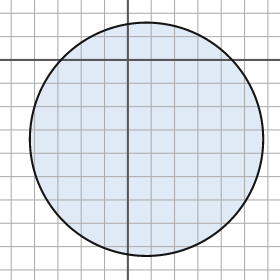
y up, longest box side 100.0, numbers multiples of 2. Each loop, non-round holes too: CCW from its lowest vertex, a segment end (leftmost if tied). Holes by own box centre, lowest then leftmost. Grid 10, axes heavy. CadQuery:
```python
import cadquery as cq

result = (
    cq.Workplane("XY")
    .moveTo(8.0, -34.0)
    .circle(50.0)
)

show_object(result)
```